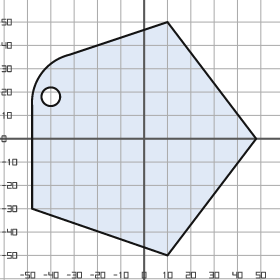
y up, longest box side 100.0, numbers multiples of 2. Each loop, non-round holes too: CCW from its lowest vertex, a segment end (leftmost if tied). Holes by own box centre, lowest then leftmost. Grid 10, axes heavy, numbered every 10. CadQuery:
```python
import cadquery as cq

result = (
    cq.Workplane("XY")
    .moveTo(10.0, -50.0)
    .lineTo(48.0, 0.0)
    .lineTo(10.0, 50.0)
    .lineTo(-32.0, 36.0)
    .threePointArc((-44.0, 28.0), (-48.0, 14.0))
    .lineTo(-48.0, -30.0)
    .close()
    .moveTo(-40.0, 18.0)
    .circle(4.0)
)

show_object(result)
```